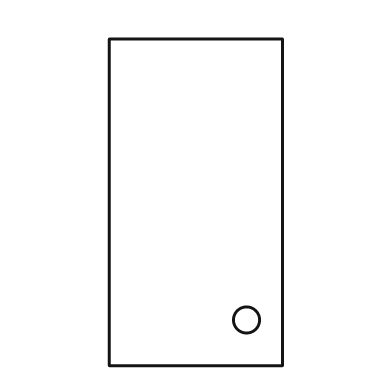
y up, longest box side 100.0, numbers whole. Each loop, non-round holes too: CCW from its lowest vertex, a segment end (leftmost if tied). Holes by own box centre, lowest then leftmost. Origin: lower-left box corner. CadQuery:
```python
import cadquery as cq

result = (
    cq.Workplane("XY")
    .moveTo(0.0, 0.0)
    .lineTo(53.0, 0.0)
    .lineTo(53.0, 100.0)
    .lineTo(0.0, 100.0)
    .close()
    .moveTo(42.0, 14.0)
    .circle(4.0)
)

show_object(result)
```